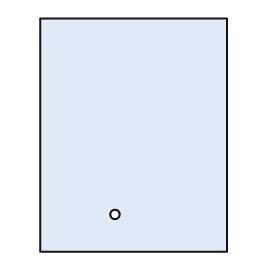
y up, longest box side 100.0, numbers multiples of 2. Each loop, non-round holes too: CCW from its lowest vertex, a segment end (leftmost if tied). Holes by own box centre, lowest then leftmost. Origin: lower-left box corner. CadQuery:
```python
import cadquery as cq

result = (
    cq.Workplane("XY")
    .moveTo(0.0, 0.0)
    .lineTo(80.0, 0.0)
    .lineTo(80.0, 100.0)
    .lineTo(0.0, 100.0)
    .close()
    .moveTo(32.0, 16.0)
    .circle(2.0)
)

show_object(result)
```